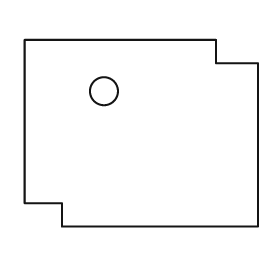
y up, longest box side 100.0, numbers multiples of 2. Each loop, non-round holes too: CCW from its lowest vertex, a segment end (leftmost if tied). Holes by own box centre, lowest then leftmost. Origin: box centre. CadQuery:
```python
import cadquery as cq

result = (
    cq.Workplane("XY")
    .moveTo(-34.0, -40.0)
    .lineTo(50.0, -40.0)
    .lineTo(50.0, 30.0)
    .lineTo(32.0, 30.0)
    .lineTo(32.0, 40.0)
    .lineTo(-50.0, 40.0)
    .lineTo(-50.0, -30.0)
    .lineTo(-34.0, -30.0)
    .close()
    .moveTo(-16.0, 18.0)
    .circle(6.0)
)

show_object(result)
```